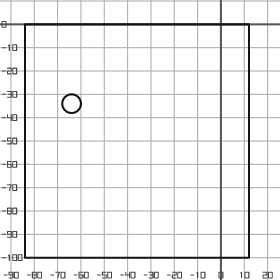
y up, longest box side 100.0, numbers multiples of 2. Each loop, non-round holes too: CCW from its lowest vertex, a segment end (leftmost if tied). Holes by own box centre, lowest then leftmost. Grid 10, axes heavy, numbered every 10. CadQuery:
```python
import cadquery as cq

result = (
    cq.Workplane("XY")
    .moveTo(-84.0, -100.0)
    .lineTo(12.0, -100.0)
    .lineTo(12.0, 0.0)
    .lineTo(-84.0, 0.0)
    .close()
    .moveTo(-64.0, -34.0)
    .circle(4.0)
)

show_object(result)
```